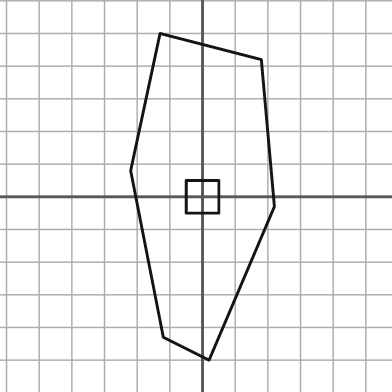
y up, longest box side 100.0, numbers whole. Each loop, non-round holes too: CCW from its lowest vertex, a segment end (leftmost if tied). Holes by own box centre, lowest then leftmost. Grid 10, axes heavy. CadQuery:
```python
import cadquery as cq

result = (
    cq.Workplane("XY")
    .moveTo(2.0, -50.0)
    .lineTo(22.0, -3.0)
    .lineTo(18.0, 42.0)
    .lineTo(-13.0, 50.0)
    .lineTo(-22.0, 8.0)
    .lineTo(-12.0, -43.0)
    .close()
    .moveTo(-5.0, -5.0)
    .lineTo(5.0, -5.0)
    .lineTo(5.0, 5.0)
    .lineTo(-5.0, 5.0)
    .close()
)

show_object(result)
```